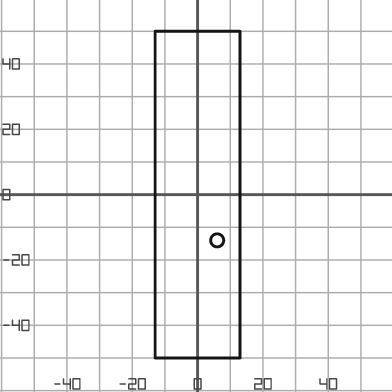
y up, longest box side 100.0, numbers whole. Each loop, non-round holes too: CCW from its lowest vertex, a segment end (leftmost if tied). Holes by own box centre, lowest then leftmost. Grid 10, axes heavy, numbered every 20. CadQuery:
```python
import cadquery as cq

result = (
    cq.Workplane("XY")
    .moveTo(-13.0, -50.0)
    .lineTo(13.0, -50.0)
    .lineTo(13.0, 50.0)
    .lineTo(-13.0, 50.0)
    .close()
    .moveTo(6.0, -14.0)
    .circle(2.0)
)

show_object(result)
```